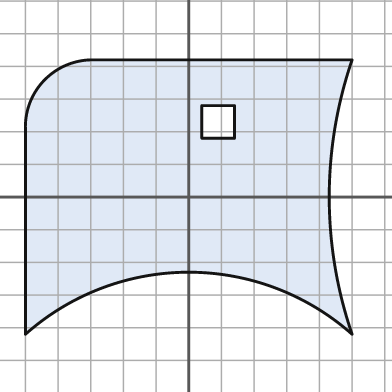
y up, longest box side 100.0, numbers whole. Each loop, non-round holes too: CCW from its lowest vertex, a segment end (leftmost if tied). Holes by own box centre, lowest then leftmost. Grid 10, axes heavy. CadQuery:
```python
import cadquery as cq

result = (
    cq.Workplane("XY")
    .moveTo(-50.0, -42.0)
    .threePointArc((0.0, -23.0), (50.0, -42.0))
    .threePointArc((43.0, 0.0), (50.0, 42.0))
    .lineTo(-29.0, 42.0)
    .threePointArc((-44.0, 36.0), (-50.0, 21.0))
    .close()
    .moveTo(4.0, 18.0)
    .lineTo(14.0, 18.0)
    .lineTo(14.0, 28.0)
    .lineTo(4.0, 28.0)
    .close()
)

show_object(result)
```